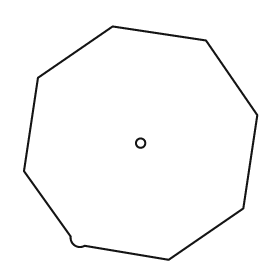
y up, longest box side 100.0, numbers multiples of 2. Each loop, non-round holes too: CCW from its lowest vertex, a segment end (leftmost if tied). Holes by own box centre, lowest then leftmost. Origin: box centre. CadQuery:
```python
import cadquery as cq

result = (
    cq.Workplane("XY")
    .moveTo(12.0, -50.0)
    .lineTo(44.0, -28.0)
    .lineTo(50.0, 12.0)
    .lineTo(28.0, 44.0)
    .lineTo(-12.0, 50.0)
    .lineTo(-44.0, 28.0)
    .lineTo(-50.0, -12.0)
    .lineTo(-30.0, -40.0)
    .threePointArc((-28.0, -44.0), (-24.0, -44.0))
    .close()
    .moveTo(0.0, 0.0)
    .circle(2.0)
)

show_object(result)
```